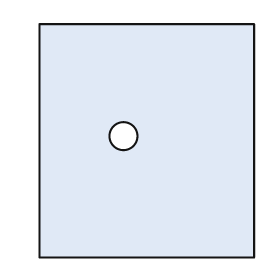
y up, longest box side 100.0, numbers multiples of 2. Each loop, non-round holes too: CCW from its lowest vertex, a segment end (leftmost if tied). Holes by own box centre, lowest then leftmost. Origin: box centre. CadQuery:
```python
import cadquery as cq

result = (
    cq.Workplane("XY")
    .moveTo(-46.0, -50.0)
    .lineTo(46.0, -50.0)
    .lineTo(46.0, 50.0)
    .lineTo(-46.0, 50.0)
    .close()
    .moveTo(-10.0, 2.0)
    .circle(6.0)
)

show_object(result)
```